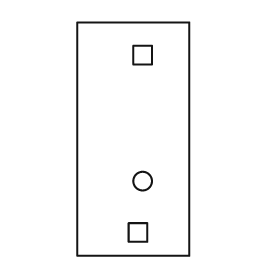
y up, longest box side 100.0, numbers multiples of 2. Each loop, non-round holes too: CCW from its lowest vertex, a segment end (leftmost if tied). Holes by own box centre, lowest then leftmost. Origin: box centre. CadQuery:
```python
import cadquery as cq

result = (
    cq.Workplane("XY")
    .moveTo(-24.0, -50.0)
    .lineTo(24.0, -50.0)
    .lineTo(24.0, 50.0)
    .lineTo(-24.0, 50.0)
    .close()
    .moveTo(-2.0, -44.0)
    .lineTo(6.0, -44.0)
    .lineTo(6.0, -36.0)
    .lineTo(-2.0, -36.0)
    .close()
    .moveTo(4.0, -18.0)
    .circle(4.0)
    .moveTo(0.0, 32.0)
    .lineTo(8.0, 32.0)
    .lineTo(8.0, 40.0)
    .lineTo(0.0, 40.0)
    .close()
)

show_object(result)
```